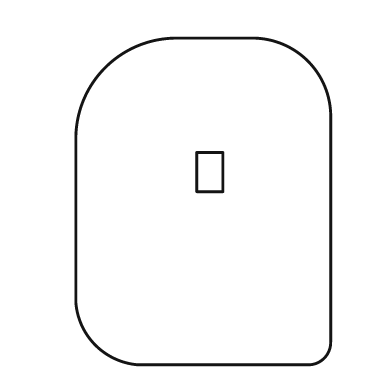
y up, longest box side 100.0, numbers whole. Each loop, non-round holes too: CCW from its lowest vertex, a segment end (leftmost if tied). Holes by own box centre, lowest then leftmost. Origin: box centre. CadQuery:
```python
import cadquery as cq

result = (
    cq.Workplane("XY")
    .moveTo(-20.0, -50.0)
    .lineTo(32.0, -50.0)
    .threePointArc((37.0, -48.0), (39.0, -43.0))
    .lineTo(39.0, 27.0)
    .threePointArc((32.0, 43.0), (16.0, 50.0))
    .lineTo(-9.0, 50.0)
    .threePointArc((-30.0, 41.0), (-39.0, 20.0))
    .lineTo(-39.0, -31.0)
    .threePointArc((-33.0, -44.0), (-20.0, -50.0))
    .close()
    .moveTo(-2.0, 3.0)
    .lineTo(6.0, 3.0)
    .lineTo(6.0, 15.0)
    .lineTo(-2.0, 15.0)
    .close()
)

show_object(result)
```